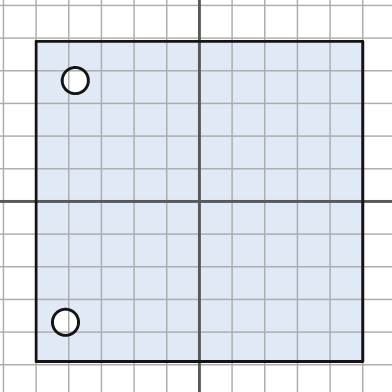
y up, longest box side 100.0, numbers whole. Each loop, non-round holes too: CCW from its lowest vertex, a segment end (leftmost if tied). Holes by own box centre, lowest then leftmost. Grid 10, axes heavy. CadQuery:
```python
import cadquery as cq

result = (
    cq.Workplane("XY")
    .moveTo(-50.0, -49.0)
    .lineTo(50.0, -49.0)
    .lineTo(50.0, 49.0)
    .lineTo(-50.0, 49.0)
    .close()
    .moveTo(-41.0, -37.0)
    .circle(4.0)
    .moveTo(-38.0, 37.0)
    .circle(4.0)
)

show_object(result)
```